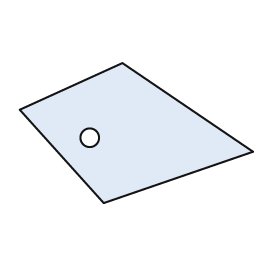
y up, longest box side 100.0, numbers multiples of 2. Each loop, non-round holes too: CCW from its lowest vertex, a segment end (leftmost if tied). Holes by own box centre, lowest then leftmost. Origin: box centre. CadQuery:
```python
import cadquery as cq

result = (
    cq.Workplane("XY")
    .moveTo(-14.0, -30.0)
    .lineTo(50.0, -8.0)
    .lineTo(-6.0, 30.0)
    .lineTo(-50.0, 10.0)
    .close()
    .moveTo(-20.0, -2.0)
    .circle(4.0)
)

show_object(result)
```